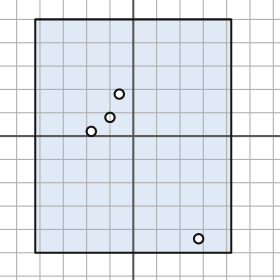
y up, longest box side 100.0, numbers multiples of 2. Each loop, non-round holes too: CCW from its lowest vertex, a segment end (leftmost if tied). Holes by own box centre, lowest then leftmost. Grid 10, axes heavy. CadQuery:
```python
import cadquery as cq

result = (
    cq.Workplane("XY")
    .moveTo(-42.0, -50.0)
    .lineTo(42.0, -50.0)
    .lineTo(42.0, 50.0)
    .lineTo(-42.0, 50.0)
    .close()
    .moveTo(28.0, -44.0)
    .circle(2.0)
    .moveTo(-18.0, 2.0)
    .circle(2.0)
    .moveTo(-10.0, 8.0)
    .circle(2.0)
    .moveTo(-6.0, 18.0)
    .circle(2.0)
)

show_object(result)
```